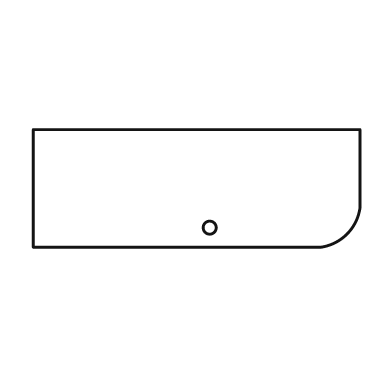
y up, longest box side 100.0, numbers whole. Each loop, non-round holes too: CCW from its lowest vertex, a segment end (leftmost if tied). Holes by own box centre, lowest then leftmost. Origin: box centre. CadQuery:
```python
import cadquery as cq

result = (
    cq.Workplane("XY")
    .moveTo(-50.0, -18.0)
    .lineTo(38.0, -18.0)
    .threePointArc((46.0, -14.0), (50.0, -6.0))
    .lineTo(50.0, 18.0)
    .lineTo(-50.0, 18.0)
    .close()
    .moveTo(4.0, -12.0)
    .circle(2.0)
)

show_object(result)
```